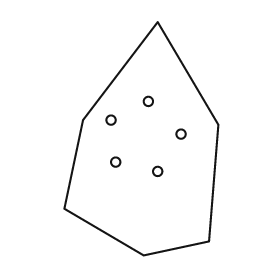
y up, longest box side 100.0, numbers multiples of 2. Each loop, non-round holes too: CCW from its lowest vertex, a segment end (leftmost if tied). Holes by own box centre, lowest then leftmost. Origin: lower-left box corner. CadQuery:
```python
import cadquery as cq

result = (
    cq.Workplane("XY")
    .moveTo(34.0, 0.0)
    .lineTo(62.0, 6.0)
    .lineTo(66.0, 56.0)
    .lineTo(40.0, 100.0)
    .lineTo(8.0, 58.0)
    .lineTo(0.0, 20.0)
    .close()
    .moveTo(40.0, 36.0)
    .circle(2.0)
    .moveTo(22.0, 40.0)
    .circle(2.0)
    .moveTo(50.0, 52.0)
    .circle(2.0)
    .moveTo(20.0, 58.0)
    .circle(2.0)
    .moveTo(36.0, 66.0)
    .circle(2.0)
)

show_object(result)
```